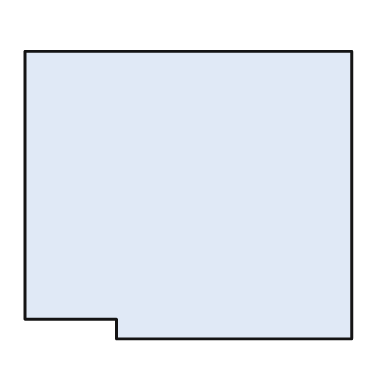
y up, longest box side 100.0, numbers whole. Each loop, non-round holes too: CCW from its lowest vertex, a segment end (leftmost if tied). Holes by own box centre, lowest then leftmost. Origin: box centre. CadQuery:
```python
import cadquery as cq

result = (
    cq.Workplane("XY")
    .moveTo(-22.0, -44.0)
    .lineTo(50.0, -44.0)
    .lineTo(50.0, 44.0)
    .lineTo(-50.0, 44.0)
    .lineTo(-50.0, -38.0)
    .lineTo(-22.0, -38.0)
    .close()
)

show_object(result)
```